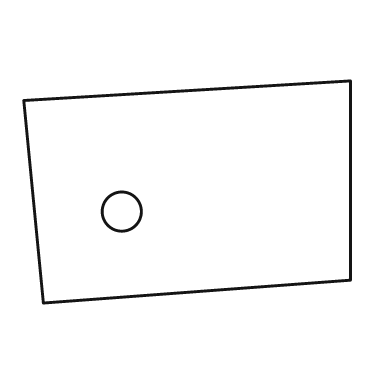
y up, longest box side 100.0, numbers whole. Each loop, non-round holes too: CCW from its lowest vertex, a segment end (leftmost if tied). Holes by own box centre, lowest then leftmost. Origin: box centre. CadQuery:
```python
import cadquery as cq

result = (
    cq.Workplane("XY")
    .moveTo(-44.0, -34.0)
    .lineTo(50.0, -27.0)
    .lineTo(50.0, 34.0)
    .lineTo(-50.0, 28.0)
    .close()
    .moveTo(-20.0, -6.0)
    .circle(6.0)
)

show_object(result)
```